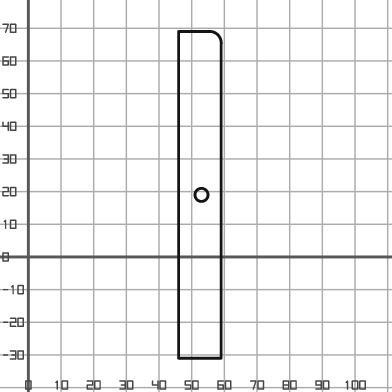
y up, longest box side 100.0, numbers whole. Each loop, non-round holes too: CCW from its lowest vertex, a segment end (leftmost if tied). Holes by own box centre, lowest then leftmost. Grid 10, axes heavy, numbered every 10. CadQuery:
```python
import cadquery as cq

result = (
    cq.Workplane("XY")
    .moveTo(46.0, -31.0)
    .lineTo(59.0, -31.0)
    .lineTo(59.0, 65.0)
    .threePointArc((58.0, 68.0), (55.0, 69.0))
    .lineTo(46.0, 69.0)
    .close()
    .moveTo(53.0, 19.0)
    .circle(2.0)
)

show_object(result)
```